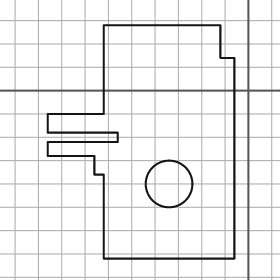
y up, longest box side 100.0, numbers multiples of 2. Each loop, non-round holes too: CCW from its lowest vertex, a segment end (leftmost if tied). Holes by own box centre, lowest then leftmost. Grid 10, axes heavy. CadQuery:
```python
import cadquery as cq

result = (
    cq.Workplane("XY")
    .moveTo(-62.0, -72.0)
    .lineTo(-6.0, -72.0)
    .lineTo(-6.0, 14.0)
    .lineTo(-12.0, 14.0)
    .lineTo(-12.0, 28.0)
    .lineTo(-62.0, 28.0)
    .lineTo(-62.0, -10.0)
    .lineTo(-86.0, -10.0)
    .lineTo(-86.0, -18.0)
    .lineTo(-56.0, -18.0)
    .lineTo(-56.0, -22.0)
    .lineTo(-86.0, -22.0)
    .lineTo(-86.0, -28.0)
    .lineTo(-66.0, -28.0)
    .lineTo(-66.0, -36.0)
    .lineTo(-62.0, -36.0)
    .close()
    .moveTo(-34.0, -40.0)
    .circle(10.0)
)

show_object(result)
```